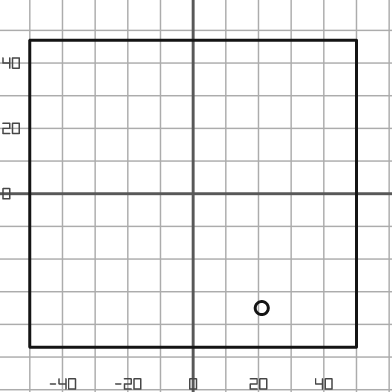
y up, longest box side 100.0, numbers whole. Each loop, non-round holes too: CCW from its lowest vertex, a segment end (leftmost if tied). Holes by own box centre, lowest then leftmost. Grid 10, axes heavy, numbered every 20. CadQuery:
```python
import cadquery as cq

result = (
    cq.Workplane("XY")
    .moveTo(-50.0, -47.0)
    .lineTo(50.0, -47.0)
    .lineTo(50.0, 47.0)
    .lineTo(-50.0, 47.0)
    .close()
    .moveTo(21.0, -35.0)
    .circle(2.0)
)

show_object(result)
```